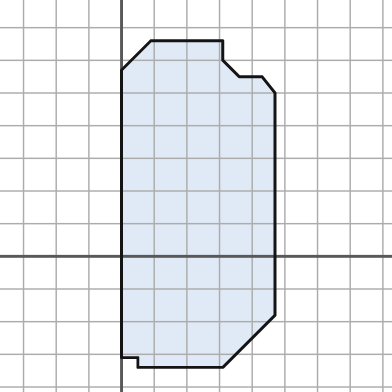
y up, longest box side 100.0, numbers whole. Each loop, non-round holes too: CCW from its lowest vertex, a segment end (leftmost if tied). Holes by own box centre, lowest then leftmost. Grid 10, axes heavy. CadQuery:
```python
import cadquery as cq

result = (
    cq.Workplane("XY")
    .moveTo(5.0, -34.0)
    .lineTo(31.0, -34.0)
    .lineTo(47.0, -18.0)
    .lineTo(47.0, 50.0)
    .lineTo(43.0, 55.0)
    .lineTo(36.0, 55.0)
    .lineTo(31.0, 60.0)
    .lineTo(31.0, 66.0)
    .lineTo(9.0, 66.0)
    .lineTo(0.0, 57.0)
    .lineTo(0.0, -31.0)
    .lineTo(5.0, -31.0)
    .close()
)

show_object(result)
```